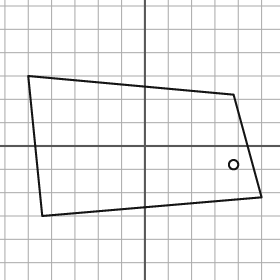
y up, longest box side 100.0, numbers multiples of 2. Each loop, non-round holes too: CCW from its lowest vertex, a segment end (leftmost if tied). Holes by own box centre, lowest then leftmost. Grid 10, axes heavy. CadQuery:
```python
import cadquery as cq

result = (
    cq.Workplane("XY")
    .moveTo(-44.0, -30.0)
    .lineTo(50.0, -22.0)
    .lineTo(38.0, 22.0)
    .lineTo(-50.0, 30.0)
    .close()
    .moveTo(38.0, -8.0)
    .circle(2.0)
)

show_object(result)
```